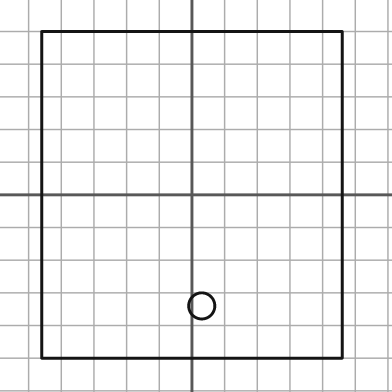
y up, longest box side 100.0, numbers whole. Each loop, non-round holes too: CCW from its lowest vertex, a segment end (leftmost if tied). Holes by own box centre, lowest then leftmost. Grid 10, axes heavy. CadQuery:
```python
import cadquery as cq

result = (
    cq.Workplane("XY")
    .moveTo(-46.0, -50.0)
    .lineTo(46.0, -50.0)
    .lineTo(46.0, 50.0)
    .lineTo(-46.0, 50.0)
    .close()
    .moveTo(3.0, -34.0)
    .circle(4.0)
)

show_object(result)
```